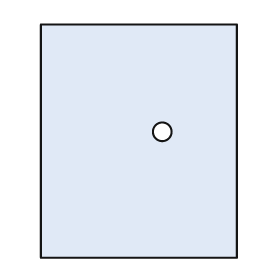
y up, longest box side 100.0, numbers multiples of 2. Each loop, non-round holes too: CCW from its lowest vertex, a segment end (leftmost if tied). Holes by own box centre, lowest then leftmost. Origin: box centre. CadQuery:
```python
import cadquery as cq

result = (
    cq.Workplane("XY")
    .moveTo(-42.0, -50.0)
    .lineTo(42.0, -50.0)
    .lineTo(42.0, 50.0)
    .lineTo(-42.0, 50.0)
    .close()
    .moveTo(10.0, 4.0)
    .circle(4.0)
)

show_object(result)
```